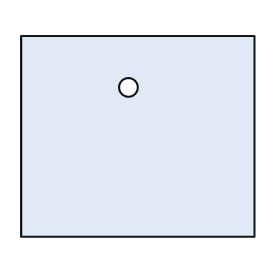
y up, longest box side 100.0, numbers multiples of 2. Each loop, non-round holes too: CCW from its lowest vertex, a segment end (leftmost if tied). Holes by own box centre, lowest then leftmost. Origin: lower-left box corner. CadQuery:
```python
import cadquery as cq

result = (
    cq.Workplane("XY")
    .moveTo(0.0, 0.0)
    .lineTo(100.0, 0.0)
    .lineTo(100.0, 86.0)
    .lineTo(0.0, 86.0)
    .close()
    .moveTo(46.0, 64.0)
    .circle(4.0)
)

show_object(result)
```